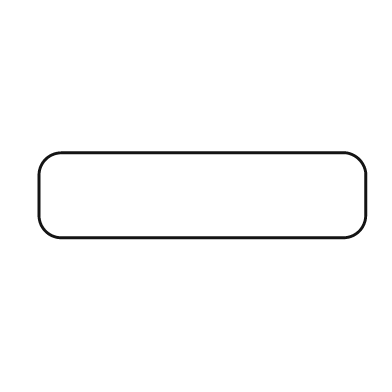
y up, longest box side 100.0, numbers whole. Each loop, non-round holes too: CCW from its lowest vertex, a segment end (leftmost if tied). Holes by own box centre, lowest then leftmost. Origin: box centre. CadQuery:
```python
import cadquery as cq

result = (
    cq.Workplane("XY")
    .moveTo(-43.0, -13.0)
    .lineTo(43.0, -13.0)
    .threePointArc((48.0, -11.0), (50.0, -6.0))
    .lineTo(50.0, 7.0)
    .threePointArc((48.0, 11.0), (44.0, 13.0))
    .lineTo(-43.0, 13.0)
    .threePointArc((-48.0, 11.0), (-50.0, 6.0))
    .lineTo(-50.0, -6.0)
    .threePointArc((-48.0, -11.0), (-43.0, -13.0))
    .close()
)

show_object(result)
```